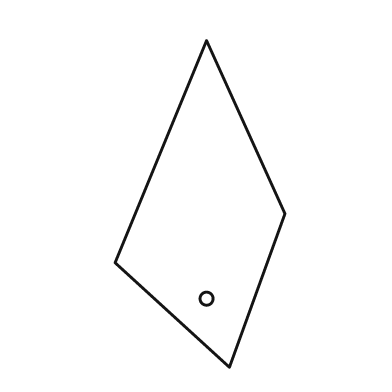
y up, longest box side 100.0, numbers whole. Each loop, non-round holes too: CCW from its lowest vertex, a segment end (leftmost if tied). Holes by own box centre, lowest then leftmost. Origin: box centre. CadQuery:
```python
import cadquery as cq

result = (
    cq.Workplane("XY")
    .moveTo(9.0, -50.0)
    .lineTo(26.0, -3.0)
    .lineTo(2.0, 50.0)
    .lineTo(-26.0, -18.0)
    .close()
    .moveTo(2.0, -29.0)
    .circle(2.0)
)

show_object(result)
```